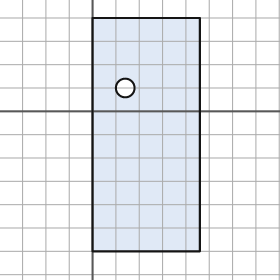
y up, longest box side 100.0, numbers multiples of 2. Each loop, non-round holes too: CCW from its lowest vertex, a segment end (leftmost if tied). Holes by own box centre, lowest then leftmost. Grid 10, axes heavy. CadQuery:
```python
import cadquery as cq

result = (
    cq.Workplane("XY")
    .moveTo(0.0, -60.0)
    .lineTo(46.0, -60.0)
    .lineTo(46.0, 40.0)
    .lineTo(0.0, 40.0)
    .close()
    .moveTo(14.0, 10.0)
    .circle(4.0)
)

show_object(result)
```